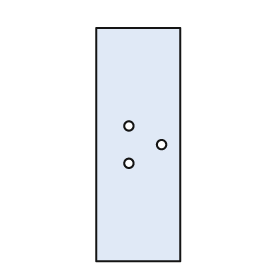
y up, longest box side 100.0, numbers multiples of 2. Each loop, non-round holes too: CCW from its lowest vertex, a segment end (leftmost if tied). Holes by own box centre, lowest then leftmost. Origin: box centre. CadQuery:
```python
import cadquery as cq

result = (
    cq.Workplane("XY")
    .moveTo(-18.0, -50.0)
    .lineTo(18.0, -50.0)
    .lineTo(18.0, 50.0)
    .lineTo(-18.0, 50.0)
    .close()
    .moveTo(-4.0, -8.0)
    .circle(2.0)
    .moveTo(10.0, 0.0)
    .circle(2.0)
    .moveTo(-4.0, 8.0)
    .circle(2.0)
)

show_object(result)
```